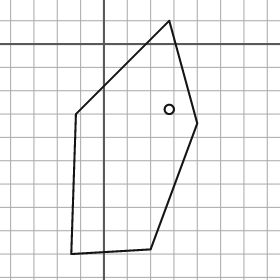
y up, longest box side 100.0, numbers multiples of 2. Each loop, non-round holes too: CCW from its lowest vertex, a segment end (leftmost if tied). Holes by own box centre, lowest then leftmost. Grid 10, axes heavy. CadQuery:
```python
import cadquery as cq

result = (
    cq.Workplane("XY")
    .moveTo(-14.0, -90.0)
    .lineTo(20.0, -88.0)
    .lineTo(40.0, -34.0)
    .lineTo(28.0, 10.0)
    .lineTo(-12.0, -30.0)
    .close()
    .moveTo(28.0, -28.0)
    .circle(2.0)
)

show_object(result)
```